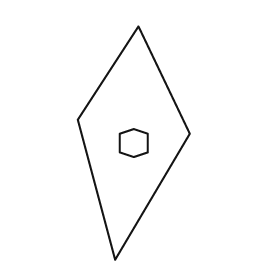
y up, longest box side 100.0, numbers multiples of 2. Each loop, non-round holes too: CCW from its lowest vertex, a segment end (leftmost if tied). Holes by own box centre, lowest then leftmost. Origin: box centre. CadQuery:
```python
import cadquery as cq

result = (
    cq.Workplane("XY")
    .moveTo(-8.0, -50.0)
    .lineTo(24.0, 4.0)
    .lineTo(2.0, 50.0)
    .lineTo(-24.0, 10.0)
    .close()
    .moveTo(0.0, -6.0)
    .lineTo(6.0, -4.0)
    .lineTo(6.0, 4.0)
    .lineTo(0.0, 6.0)
    .lineTo(-6.0, 4.0)
    .lineTo(-6.0, -4.0)
    .close()
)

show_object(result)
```